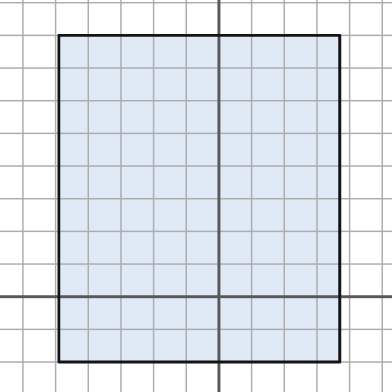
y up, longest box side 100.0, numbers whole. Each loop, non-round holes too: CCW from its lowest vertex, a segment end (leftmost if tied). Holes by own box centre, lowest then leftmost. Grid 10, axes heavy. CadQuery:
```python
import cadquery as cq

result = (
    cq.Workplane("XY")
    .moveTo(-49.0, -20.0)
    .lineTo(37.0, -20.0)
    .lineTo(37.0, 80.0)
    .lineTo(-49.0, 80.0)
    .close()
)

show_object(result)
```